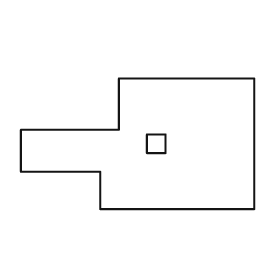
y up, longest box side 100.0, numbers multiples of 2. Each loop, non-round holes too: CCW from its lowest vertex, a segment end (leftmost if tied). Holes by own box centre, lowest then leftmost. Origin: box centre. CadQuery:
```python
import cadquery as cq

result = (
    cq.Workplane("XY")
    .moveTo(-16.0, -28.0)
    .lineTo(50.0, -28.0)
    .lineTo(50.0, 28.0)
    .lineTo(-8.0, 28.0)
    .lineTo(-8.0, 6.0)
    .lineTo(-50.0, 6.0)
    .lineTo(-50.0, -12.0)
    .lineTo(-16.0, -12.0)
    .close()
    .moveTo(4.0, -4.0)
    .lineTo(12.0, -4.0)
    .lineTo(12.0, 4.0)
    .lineTo(4.0, 4.0)
    .close()
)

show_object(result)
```